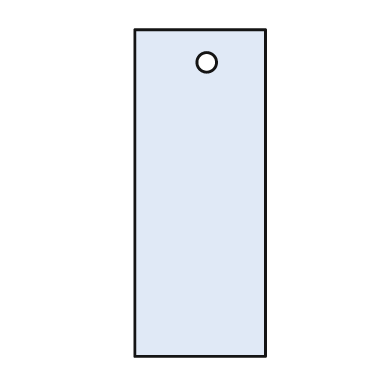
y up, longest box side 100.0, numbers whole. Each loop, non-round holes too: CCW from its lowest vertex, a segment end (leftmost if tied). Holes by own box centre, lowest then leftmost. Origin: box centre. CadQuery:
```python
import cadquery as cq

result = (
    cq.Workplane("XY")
    .moveTo(-20.0, -50.0)
    .lineTo(20.0, -50.0)
    .lineTo(20.0, 50.0)
    .lineTo(-20.0, 50.0)
    .close()
    .moveTo(2.0, 40.0)
    .circle(3.0)
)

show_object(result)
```